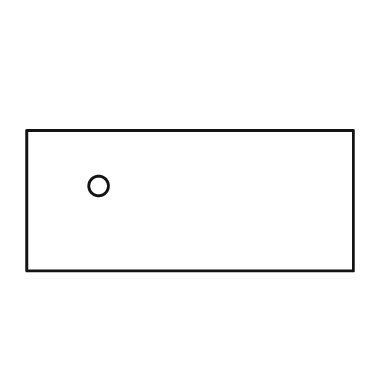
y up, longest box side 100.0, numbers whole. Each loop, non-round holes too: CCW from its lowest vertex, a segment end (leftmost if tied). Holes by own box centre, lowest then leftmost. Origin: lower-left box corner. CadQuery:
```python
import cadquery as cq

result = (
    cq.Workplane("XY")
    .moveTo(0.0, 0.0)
    .lineTo(100.0, 0.0)
    .lineTo(100.0, 43.0)
    .lineTo(0.0, 43.0)
    .close()
    .moveTo(22.0, 26.0)
    .circle(3.0)
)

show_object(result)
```